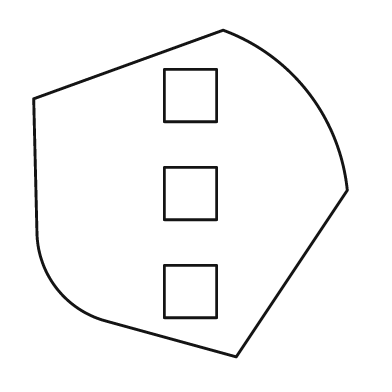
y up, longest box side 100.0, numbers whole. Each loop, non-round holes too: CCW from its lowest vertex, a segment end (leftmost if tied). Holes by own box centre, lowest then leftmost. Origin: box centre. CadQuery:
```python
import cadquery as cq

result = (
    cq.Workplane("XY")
    .moveTo(14.0, -50.0)
    .lineTo(48.0, 1.0)
    .threePointArc((36.0, 31.0), (10.0, 50.0))
    .lineTo(-48.0, 29.0)
    .lineTo(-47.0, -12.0)
    .threePointArc((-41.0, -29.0), (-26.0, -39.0))
    .close()
    .moveTo(-8.0, -38.0)
    .lineTo(8.0, -38.0)
    .lineTo(8.0, -22.0)
    .lineTo(-8.0, -22.0)
    .close()
    .moveTo(-8.0, -8.0)
    .lineTo(8.0, -8.0)
    .lineTo(8.0, 8.0)
    .lineTo(-8.0, 8.0)
    .close()
    .moveTo(-8.0, 22.0)
    .lineTo(8.0, 22.0)
    .lineTo(8.0, 38.0)
    .lineTo(-8.0, 38.0)
    .close()
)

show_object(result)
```